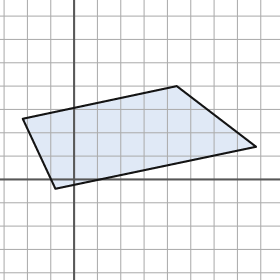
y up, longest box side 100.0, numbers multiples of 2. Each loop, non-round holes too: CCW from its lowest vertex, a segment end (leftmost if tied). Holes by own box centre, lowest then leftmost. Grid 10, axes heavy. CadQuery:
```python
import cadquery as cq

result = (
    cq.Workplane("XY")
    .moveTo(-8.0, -4.0)
    .lineTo(78.0, 14.0)
    .lineTo(44.0, 40.0)
    .lineTo(-22.0, 26.0)
    .close()
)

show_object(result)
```